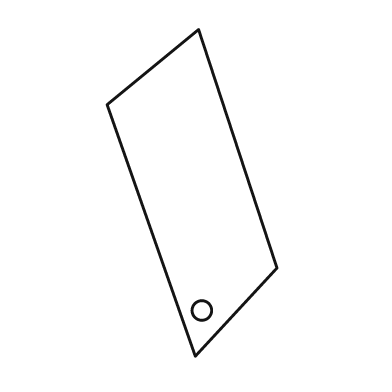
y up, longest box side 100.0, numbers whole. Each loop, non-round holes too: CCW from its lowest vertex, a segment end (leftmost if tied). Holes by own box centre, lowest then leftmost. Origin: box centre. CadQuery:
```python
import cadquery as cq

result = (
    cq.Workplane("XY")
    .moveTo(1.0, -50.0)
    .lineTo(26.0, -23.0)
    .lineTo(2.0, 50.0)
    .lineTo(-26.0, 27.0)
    .close()
    .moveTo(3.0, -36.0)
    .circle(3.0)
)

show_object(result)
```